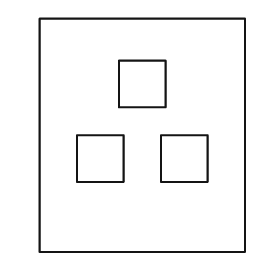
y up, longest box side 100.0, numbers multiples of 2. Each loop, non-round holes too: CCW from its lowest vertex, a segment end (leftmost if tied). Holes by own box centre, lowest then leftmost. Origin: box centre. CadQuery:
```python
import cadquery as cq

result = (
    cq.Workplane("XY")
    .moveTo(-44.0, -50.0)
    .lineTo(44.0, -50.0)
    .lineTo(44.0, 50.0)
    .lineTo(-44.0, 50.0)
    .close()
    .moveTo(-28.0, -20.0)
    .lineTo(-8.0, -20.0)
    .lineTo(-8.0, 0.0)
    .lineTo(-28.0, 0.0)
    .close()
    .moveTo(8.0, -20.0)
    .lineTo(28.0, -20.0)
    .lineTo(28.0, 0.0)
    .lineTo(8.0, 0.0)
    .close()
    .moveTo(-10.0, 12.0)
    .lineTo(10.0, 12.0)
    .lineTo(10.0, 32.0)
    .lineTo(-10.0, 32.0)
    .close()
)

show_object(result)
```